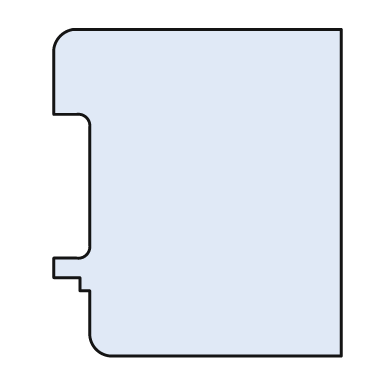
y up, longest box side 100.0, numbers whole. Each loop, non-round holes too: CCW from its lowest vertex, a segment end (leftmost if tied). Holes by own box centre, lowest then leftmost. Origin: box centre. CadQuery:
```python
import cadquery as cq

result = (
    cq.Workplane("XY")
    .moveTo(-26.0, -50.0)
    .lineTo(44.0, -50.0)
    .lineTo(44.0, 50.0)
    .lineTo(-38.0, 50.0)
    .threePointArc((-42.0, 48.0), (-44.0, 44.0))
    .lineTo(-44.0, 24.0)
    .lineTo(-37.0, 24.0)
    .threePointArc((-34.0, 23.0), (-33.0, 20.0))
    .lineTo(-33.0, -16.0)
    .threePointArc((-34.0, -19.0), (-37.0, -20.0))
    .lineTo(-44.0, -20.0)
    .lineTo(-44.0, -26.0)
    .lineTo(-36.0, -26.0)
    .lineTo(-36.0, -30.0)
    .lineTo(-33.0, -30.0)
    .lineTo(-33.0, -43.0)
    .threePointArc((-31.0, -48.0), (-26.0, -50.0))
    .close()
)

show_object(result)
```